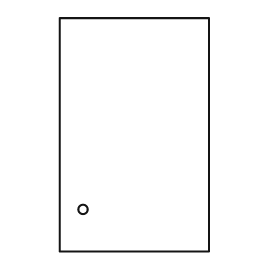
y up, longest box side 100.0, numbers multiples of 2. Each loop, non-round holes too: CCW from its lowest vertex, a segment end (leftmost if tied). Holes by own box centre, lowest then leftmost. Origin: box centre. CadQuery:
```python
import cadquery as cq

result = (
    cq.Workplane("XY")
    .moveTo(-32.0, -50.0)
    .lineTo(32.0, -50.0)
    .lineTo(32.0, 50.0)
    .lineTo(-32.0, 50.0)
    .close()
    .moveTo(-22.0, -32.0)
    .circle(2.0)
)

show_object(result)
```